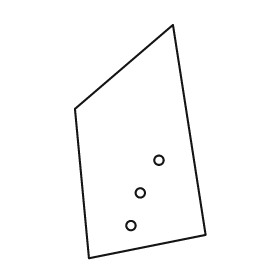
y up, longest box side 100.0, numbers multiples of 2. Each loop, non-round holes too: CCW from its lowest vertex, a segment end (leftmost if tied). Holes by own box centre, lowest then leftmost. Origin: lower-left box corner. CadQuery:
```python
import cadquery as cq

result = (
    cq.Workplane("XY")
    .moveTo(6.0, 0.0)
    .lineTo(56.0, 10.0)
    .lineTo(42.0, 100.0)
    .lineTo(0.0, 64.0)
    .close()
    .moveTo(24.0, 14.0)
    .circle(2.0)
    .moveTo(28.0, 28.0)
    .circle(2.0)
    .moveTo(36.0, 42.0)
    .circle(2.0)
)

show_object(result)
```